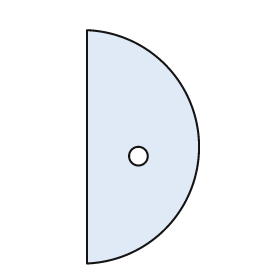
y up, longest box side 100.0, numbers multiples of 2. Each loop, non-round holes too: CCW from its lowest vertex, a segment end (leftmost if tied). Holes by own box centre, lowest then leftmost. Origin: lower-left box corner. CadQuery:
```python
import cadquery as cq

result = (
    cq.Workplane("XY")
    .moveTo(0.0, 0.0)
    .threePointArc((48.0, 50.0), (0.0, 100.0))
    .close()
    .moveTo(22.0, 46.0)
    .circle(4.0)
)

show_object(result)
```